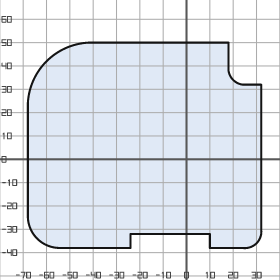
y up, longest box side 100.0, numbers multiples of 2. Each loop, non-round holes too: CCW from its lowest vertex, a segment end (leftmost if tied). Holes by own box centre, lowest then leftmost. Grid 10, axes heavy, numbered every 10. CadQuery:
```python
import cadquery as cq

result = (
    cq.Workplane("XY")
    .moveTo(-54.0, -38.0)
    .lineTo(-24.0, -38.0)
    .lineTo(-24.0, -32.0)
    .lineTo(10.0, -32.0)
    .lineTo(10.0, -38.0)
    .lineTo(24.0, -38.0)
    .threePointArc((30.0, -36.0), (32.0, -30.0))
    .lineTo(32.0, 32.0)
    .lineTo(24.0, 32.0)
    .threePointArc((20.0, 34.0), (18.0, 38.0))
    .lineTo(18.0, 50.0)
    .lineTo(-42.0, 50.0)
    .threePointArc((-60.0, 42.0), (-68.0, 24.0))
    .lineTo(-68.0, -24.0)
    .threePointArc((-64.0, -34.0), (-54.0, -38.0))
    .close()
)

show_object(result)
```